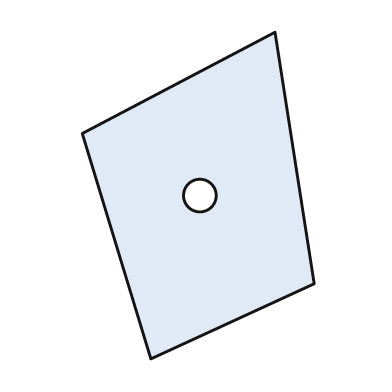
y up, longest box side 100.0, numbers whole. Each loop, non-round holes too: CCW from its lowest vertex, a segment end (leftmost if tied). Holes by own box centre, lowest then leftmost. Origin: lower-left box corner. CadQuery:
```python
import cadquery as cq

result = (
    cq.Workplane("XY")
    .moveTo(21.0, 0.0)
    .lineTo(71.0, 23.0)
    .lineTo(59.0, 100.0)
    .lineTo(0.0, 69.0)
    .close()
    .moveTo(36.0, 50.0)
    .circle(5.0)
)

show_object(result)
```